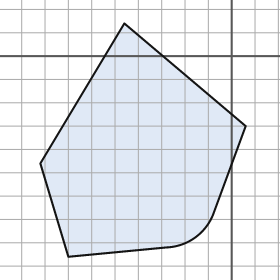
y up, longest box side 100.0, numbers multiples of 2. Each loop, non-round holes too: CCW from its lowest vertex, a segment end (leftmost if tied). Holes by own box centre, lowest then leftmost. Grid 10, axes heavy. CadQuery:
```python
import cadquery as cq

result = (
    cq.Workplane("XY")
    .moveTo(-70.0, -86.0)
    .lineTo(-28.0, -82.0)
    .threePointArc((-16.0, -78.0), (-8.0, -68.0))
    .lineTo(6.0, -30.0)
    .lineTo(-46.0, 14.0)
    .lineTo(-82.0, -46.0)
    .close()
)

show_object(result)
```